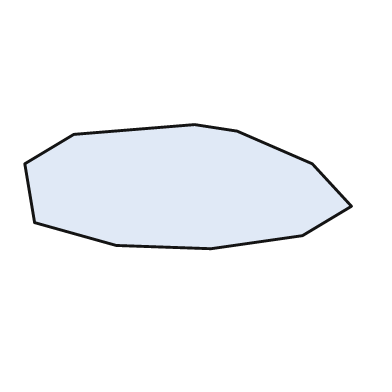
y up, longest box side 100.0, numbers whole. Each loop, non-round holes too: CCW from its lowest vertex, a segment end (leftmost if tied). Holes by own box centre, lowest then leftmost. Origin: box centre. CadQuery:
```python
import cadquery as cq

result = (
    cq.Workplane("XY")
    .moveTo(7.0, -19.0)
    .lineTo(35.0, -15.0)
    .lineTo(50.0, -6.0)
    .lineTo(38.0, 7.0)
    .lineTo(15.0, 17.0)
    .lineTo(2.0, 19.0)
    .lineTo(-35.0, 16.0)
    .lineTo(-50.0, 7.0)
    .lineTo(-47.0, -11.0)
    .lineTo(-22.0, -18.0)
    .close()
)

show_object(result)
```